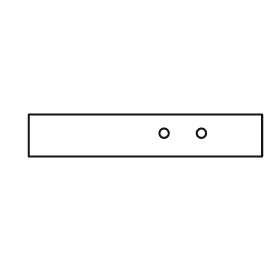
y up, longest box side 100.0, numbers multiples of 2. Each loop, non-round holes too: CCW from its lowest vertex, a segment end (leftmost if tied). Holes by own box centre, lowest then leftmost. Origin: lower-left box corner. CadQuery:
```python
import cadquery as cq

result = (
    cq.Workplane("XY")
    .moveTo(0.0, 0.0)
    .lineTo(100.0, 0.0)
    .lineTo(100.0, 18.0)
    .lineTo(0.0, 18.0)
    .close()
    .moveTo(58.0, 10.0)
    .circle(2.0)
    .moveTo(74.0, 10.0)
    .circle(2.0)
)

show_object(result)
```